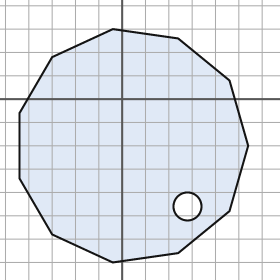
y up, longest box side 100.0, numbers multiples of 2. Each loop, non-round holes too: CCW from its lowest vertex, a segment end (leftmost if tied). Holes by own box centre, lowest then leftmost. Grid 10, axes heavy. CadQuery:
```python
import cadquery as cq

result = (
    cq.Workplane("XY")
    .moveTo(-4.0, -70.0)
    .lineTo(24.0, -66.0)
    .lineTo(46.0, -48.0)
    .lineTo(54.0, -20.0)
    .lineTo(46.0, 8.0)
    .lineTo(24.0, 26.0)
    .lineTo(-4.0, 30.0)
    .lineTo(-30.0, 18.0)
    .lineTo(-44.0, -6.0)
    .lineTo(-44.0, -34.0)
    .lineTo(-30.0, -58.0)
    .close()
    .moveTo(28.0, -46.0)
    .circle(6.0)
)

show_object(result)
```